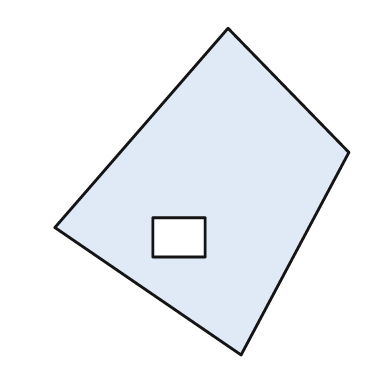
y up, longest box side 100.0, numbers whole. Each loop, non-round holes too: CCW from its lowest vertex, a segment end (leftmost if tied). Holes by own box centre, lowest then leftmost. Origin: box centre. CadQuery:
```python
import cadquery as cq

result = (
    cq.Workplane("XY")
    .moveTo(12.0, -50.0)
    .lineTo(45.0, 12.0)
    .lineTo(8.0, 50.0)
    .lineTo(-45.0, -11.0)
    .close()
    .moveTo(-15.0, -20.0)
    .lineTo(1.0, -20.0)
    .lineTo(1.0, -8.0)
    .lineTo(-15.0, -8.0)
    .close()
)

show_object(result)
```